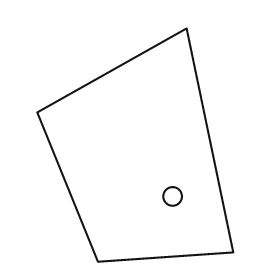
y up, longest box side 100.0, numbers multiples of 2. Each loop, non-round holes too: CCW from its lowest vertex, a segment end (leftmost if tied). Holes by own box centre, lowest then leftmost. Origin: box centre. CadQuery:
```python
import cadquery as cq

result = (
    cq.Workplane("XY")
    .moveTo(-16.0, -50.0)
    .lineTo(42.0, -46.0)
    .lineTo(22.0, 50.0)
    .lineTo(-42.0, 14.0)
    .close()
    .moveTo(16.0, -22.0)
    .circle(4.0)
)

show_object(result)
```